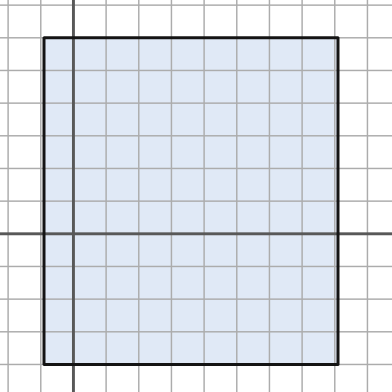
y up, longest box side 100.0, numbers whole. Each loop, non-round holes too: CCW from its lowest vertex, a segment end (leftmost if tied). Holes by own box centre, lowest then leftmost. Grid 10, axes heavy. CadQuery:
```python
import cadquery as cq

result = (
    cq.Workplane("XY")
    .moveTo(-9.0, -40.0)
    .lineTo(81.0, -40.0)
    .lineTo(81.0, 60.0)
    .lineTo(-9.0, 60.0)
    .close()
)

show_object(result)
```